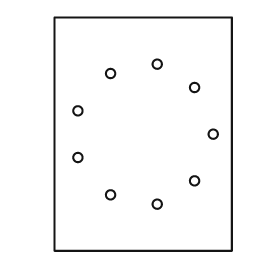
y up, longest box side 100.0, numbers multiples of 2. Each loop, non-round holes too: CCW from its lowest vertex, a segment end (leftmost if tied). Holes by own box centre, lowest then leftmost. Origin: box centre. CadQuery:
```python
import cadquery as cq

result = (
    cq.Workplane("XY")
    .moveTo(-38.0, -50.0)
    .lineTo(38.0, -50.0)
    .lineTo(38.0, 50.0)
    .lineTo(-38.0, 50.0)
    .close()
    .moveTo(6.0, -30.0)
    .circle(2.0)
    .moveTo(-14.0, -26.0)
    .circle(2.0)
    .moveTo(22.0, -20.0)
    .circle(2.0)
    .moveTo(-28.0, -10.0)
    .circle(2.0)
    .moveTo(30.0, 0.0)
    .circle(2.0)
    .moveTo(-28.0, 10.0)
    .circle(2.0)
    .moveTo(22.0, 20.0)
    .circle(2.0)
    .moveTo(-14.0, 26.0)
    .circle(2.0)
    .moveTo(6.0, 30.0)
    .circle(2.0)
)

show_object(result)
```